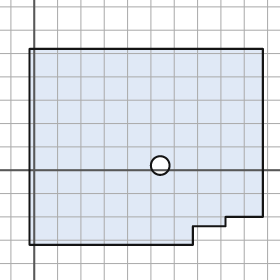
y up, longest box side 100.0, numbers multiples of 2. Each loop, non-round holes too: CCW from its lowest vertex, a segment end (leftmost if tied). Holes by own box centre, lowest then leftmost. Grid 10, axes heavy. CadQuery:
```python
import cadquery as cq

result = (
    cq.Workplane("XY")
    .moveTo(-2.0, -32.0)
    .lineTo(68.0, -32.0)
    .lineTo(68.0, -24.0)
    .lineTo(82.0, -24.0)
    .lineTo(82.0, -20.0)
    .lineTo(98.0, -20.0)
    .lineTo(98.0, 52.0)
    .lineTo(-2.0, 52.0)
    .close()
    .moveTo(54.0, 2.0)
    .circle(4.0)
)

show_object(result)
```